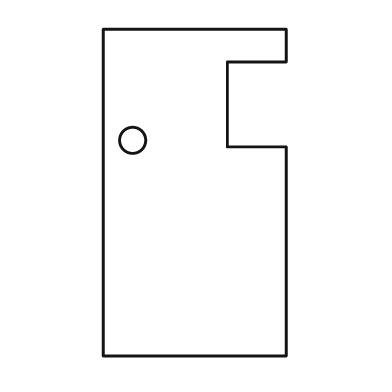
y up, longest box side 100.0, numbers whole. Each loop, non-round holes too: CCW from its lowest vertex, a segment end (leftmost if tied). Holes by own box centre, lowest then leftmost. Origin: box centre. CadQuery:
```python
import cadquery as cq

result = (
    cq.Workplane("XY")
    .moveTo(-28.0, -50.0)
    .lineTo(28.0, -50.0)
    .lineTo(28.0, 14.0)
    .lineTo(10.0, 14.0)
    .lineTo(10.0, 40.0)
    .lineTo(28.0, 40.0)
    .lineTo(28.0, 50.0)
    .lineTo(-28.0, 50.0)
    .close()
    .moveTo(-19.0, 16.0)
    .circle(4.0)
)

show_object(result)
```